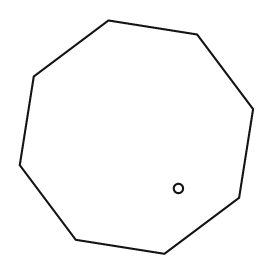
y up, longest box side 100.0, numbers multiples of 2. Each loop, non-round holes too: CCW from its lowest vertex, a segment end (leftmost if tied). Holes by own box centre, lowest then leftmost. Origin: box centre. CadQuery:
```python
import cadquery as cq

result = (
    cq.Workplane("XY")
    .moveTo(12.0, -50.0)
    .lineTo(44.0, -26.0)
    .lineTo(50.0, 12.0)
    .lineTo(26.0, 44.0)
    .lineTo(-12.0, 50.0)
    .lineTo(-44.0, 26.0)
    .lineTo(-50.0, -12.0)
    .lineTo(-26.0, -44.0)
    .close()
    .moveTo(18.0, -22.0)
    .circle(2.0)
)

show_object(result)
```